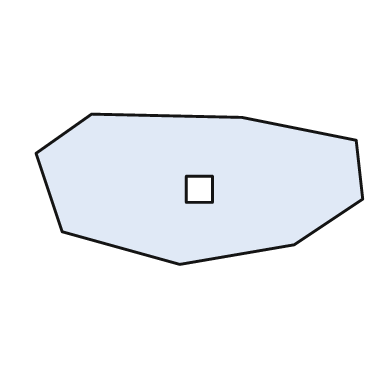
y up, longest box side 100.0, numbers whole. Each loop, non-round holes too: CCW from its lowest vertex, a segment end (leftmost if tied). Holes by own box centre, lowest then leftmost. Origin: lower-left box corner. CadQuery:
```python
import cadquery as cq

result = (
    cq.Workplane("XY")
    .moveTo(44.0, 0.0)
    .lineTo(79.0, 6.0)
    .lineTo(100.0, 20.0)
    .lineTo(98.0, 38.0)
    .lineTo(63.0, 45.0)
    .lineTo(17.0, 46.0)
    .lineTo(0.0, 34.0)
    .lineTo(8.0, 10.0)
    .close()
    .moveTo(46.0, 19.0)
    .lineTo(54.0, 19.0)
    .lineTo(54.0, 27.0)
    .lineTo(46.0, 27.0)
    .close()
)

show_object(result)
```